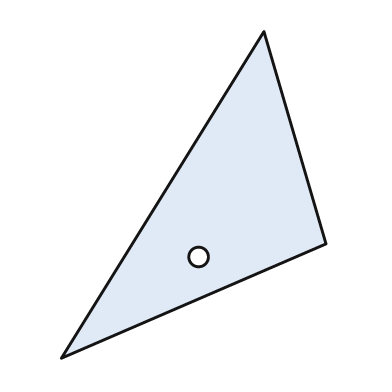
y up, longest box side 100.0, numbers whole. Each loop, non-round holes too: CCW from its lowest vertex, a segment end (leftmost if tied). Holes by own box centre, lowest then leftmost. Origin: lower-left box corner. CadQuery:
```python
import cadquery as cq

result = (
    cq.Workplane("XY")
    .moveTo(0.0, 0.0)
    .lineTo(81.0, 35.0)
    .lineTo(62.0, 100.0)
    .close()
    .moveTo(42.0, 31.0)
    .circle(3.0)
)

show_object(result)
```